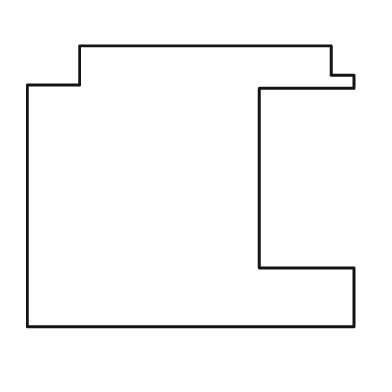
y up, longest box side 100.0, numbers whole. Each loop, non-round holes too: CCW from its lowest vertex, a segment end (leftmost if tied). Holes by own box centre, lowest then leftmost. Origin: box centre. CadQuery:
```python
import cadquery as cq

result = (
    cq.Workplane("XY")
    .moveTo(-50.0, -43.0)
    .lineTo(50.0, -43.0)
    .lineTo(50.0, -25.0)
    .lineTo(21.0, -25.0)
    .lineTo(21.0, 30.0)
    .lineTo(50.0, 30.0)
    .lineTo(50.0, 34.0)
    .lineTo(43.0, 34.0)
    .lineTo(43.0, 43.0)
    .lineTo(-34.0, 43.0)
    .lineTo(-34.0, 31.0)
    .lineTo(-50.0, 31.0)
    .close()
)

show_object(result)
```